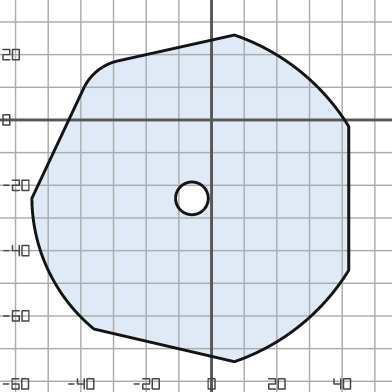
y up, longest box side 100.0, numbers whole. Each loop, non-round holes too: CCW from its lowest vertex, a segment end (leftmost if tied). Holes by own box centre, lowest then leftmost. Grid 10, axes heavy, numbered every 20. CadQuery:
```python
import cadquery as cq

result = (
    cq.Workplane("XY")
    .moveTo(7.0, -74.0)
    .threePointArc((27.0, -63.0), (42.0, -46.0))
    .lineTo(42.0, -2.0)
    .threePointArc((27.0, 15.0), (7.0, 26.0))
    .lineTo(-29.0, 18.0)
    .threePointArc((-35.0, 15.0), (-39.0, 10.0))
    .lineTo(-55.0, -24.0)
    .threePointArc((-50.0, -46.0), (-36.0, -64.0))
    .close()
    .moveTo(-6.0, -24.0)
    .circle(5.0)
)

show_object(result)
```